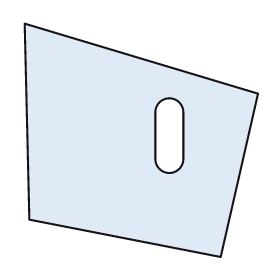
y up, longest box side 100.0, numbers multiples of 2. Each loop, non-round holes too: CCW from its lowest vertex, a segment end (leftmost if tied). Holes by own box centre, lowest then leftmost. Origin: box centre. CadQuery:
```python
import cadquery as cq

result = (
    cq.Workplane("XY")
    .moveTo(34.0, -50.0)
    .lineTo(50.0, 20.0)
    .lineTo(-50.0, 50.0)
    .lineTo(-48.0, -34.0)
    .close()
    .moveTo(6.0, -8.0)
    .threePointArc((12.0, -14.0), (18.0, -8.0))
    .lineTo(18.0, 12.0)
    .threePointArc((12.0, 18.0), (6.0, 12.0))
    .close()
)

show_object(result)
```